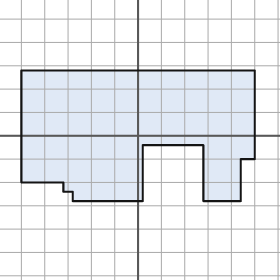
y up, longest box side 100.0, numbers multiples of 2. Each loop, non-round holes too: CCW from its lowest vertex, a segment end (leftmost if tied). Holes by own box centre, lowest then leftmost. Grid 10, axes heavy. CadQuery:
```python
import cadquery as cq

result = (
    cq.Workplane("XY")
    .moveTo(-28.0, -28.0)
    .lineTo(2.0, -28.0)
    .lineTo(2.0, -4.0)
    .lineTo(28.0, -4.0)
    .lineTo(28.0, -28.0)
    .lineTo(44.0, -28.0)
    .lineTo(44.0, -10.0)
    .lineTo(50.0, -10.0)
    .lineTo(50.0, 28.0)
    .lineTo(-50.0, 28.0)
    .lineTo(-50.0, -20.0)
    .lineTo(-32.0, -20.0)
    .lineTo(-32.0, -24.0)
    .lineTo(-28.0, -24.0)
    .close()
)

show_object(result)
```